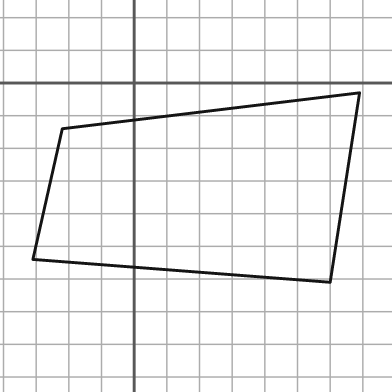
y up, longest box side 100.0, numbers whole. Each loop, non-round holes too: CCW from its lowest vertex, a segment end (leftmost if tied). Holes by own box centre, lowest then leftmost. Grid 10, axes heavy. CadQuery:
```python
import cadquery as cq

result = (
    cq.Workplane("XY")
    .moveTo(60.0, -61.0)
    .lineTo(69.0, -3.0)
    .lineTo(-22.0, -14.0)
    .lineTo(-31.0, -54.0)
    .close()
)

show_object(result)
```